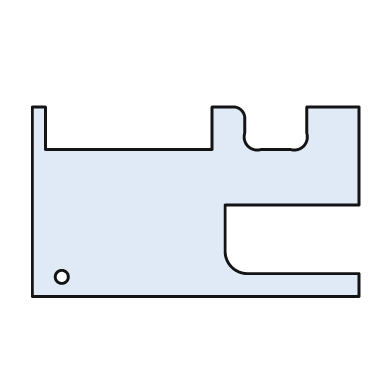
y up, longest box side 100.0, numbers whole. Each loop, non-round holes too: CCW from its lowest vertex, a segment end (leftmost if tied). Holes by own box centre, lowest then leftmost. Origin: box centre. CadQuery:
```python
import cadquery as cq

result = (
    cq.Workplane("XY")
    .moveTo(-50.0, -29.0)
    .lineTo(50.0, -29.0)
    .lineTo(50.0, -22.0)
    .lineTo(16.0, -22.0)
    .threePointArc((11.0, -20.0), (9.0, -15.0))
    .lineTo(9.0, -1.0)
    .lineTo(50.0, -1.0)
    .lineTo(50.0, 29.0)
    .lineTo(34.0, 29.0)
    .lineTo(34.0, 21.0)
    .threePointArc((33.0, 17.0), (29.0, 16.0))
    .lineTo(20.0, 16.0)
    .threePointArc((16.0, 17.0), (15.0, 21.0))
    .lineTo(15.0, 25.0)
    .threePointArc((14.0, 28.0), (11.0, 29.0))
    .lineTo(5.0, 29.0)
    .lineTo(5.0, 16.0)
    .lineTo(-46.0, 16.0)
    .lineTo(-46.0, 29.0)
    .lineTo(-50.0, 29.0)
    .close()
    .moveTo(-41.0, -23.0)
    .circle(2.0)
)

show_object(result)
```